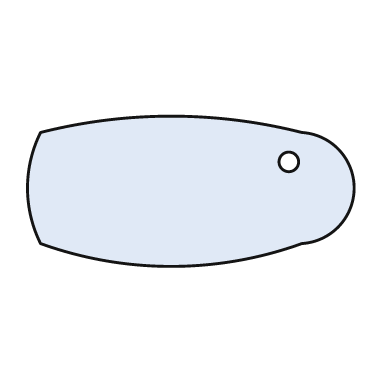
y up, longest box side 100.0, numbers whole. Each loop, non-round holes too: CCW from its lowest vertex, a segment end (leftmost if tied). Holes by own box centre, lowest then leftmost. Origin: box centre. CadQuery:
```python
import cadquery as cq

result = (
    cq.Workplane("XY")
    .moveTo(-46.0, -16.0)
    .threePointArc((-6.0, -23.0), (34.0, -16.0))
    .threePointArc((50.0, 1.0), (34.0, 18.0))
    .threePointArc((-6.0, 23.0), (-46.0, 18.0))
    .threePointArc((-50.0, 1.0), (-46.0, -16.0))
    .close()
    .moveTo(30.0, 9.0)
    .circle(3.0)
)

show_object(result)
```